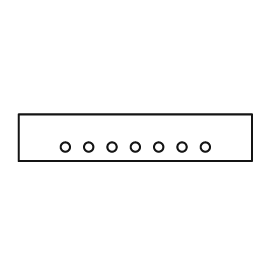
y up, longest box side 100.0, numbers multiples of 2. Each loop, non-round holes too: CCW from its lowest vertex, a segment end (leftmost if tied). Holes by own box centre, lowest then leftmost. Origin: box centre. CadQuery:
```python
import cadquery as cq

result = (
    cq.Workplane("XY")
    .moveTo(-50.0, -10.0)
    .lineTo(50.0, -10.0)
    .lineTo(50.0, 10.0)
    .lineTo(-50.0, 10.0)
    .close()
    .moveTo(-30.0, -4.0)
    .circle(2.0)
    .moveTo(-20.0, -4.0)
    .circle(2.0)
    .moveTo(-10.0, -4.0)
    .circle(2.0)
    .moveTo(0.0, -4.0)
    .circle(2.0)
    .moveTo(10.0, -4.0)
    .circle(2.0)
    .moveTo(20.0, -4.0)
    .circle(2.0)
    .moveTo(30.0, -4.0)
    .circle(2.0)
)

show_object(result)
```